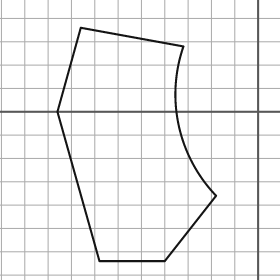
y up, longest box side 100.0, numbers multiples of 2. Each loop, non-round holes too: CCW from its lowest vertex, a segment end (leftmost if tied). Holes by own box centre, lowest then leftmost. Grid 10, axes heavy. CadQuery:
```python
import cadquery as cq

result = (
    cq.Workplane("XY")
    .moveTo(-68.0, -64.0)
    .lineTo(-40.0, -64.0)
    .lineTo(-18.0, -36.0)
    .threePointArc((-34.0, -6.0), (-32.0, 28.0))
    .lineTo(-76.0, 36.0)
    .lineTo(-86.0, 0.0)
    .close()
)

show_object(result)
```